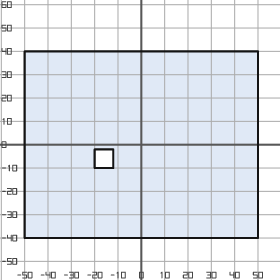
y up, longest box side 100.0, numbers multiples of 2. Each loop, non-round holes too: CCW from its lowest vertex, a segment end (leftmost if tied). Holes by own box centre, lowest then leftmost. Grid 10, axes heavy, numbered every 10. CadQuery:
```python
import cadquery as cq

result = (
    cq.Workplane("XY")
    .moveTo(-50.0, -40.0)
    .lineTo(50.0, -40.0)
    .lineTo(50.0, 40.0)
    .lineTo(-50.0, 40.0)
    .close()
    .moveTo(-20.0, -10.0)
    .lineTo(-12.0, -10.0)
    .lineTo(-12.0, -2.0)
    .lineTo(-20.0, -2.0)
    .close()
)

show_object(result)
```